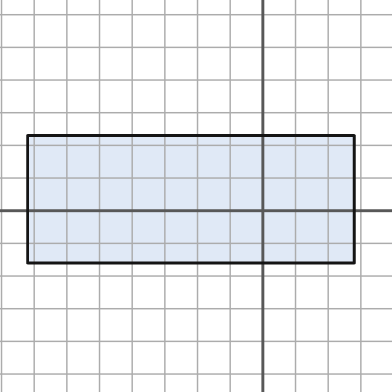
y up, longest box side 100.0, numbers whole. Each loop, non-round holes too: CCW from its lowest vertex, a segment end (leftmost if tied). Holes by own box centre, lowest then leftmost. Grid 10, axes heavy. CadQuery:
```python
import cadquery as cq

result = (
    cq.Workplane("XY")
    .moveTo(-72.0, -16.0)
    .lineTo(28.0, -16.0)
    .lineTo(28.0, 23.0)
    .lineTo(-72.0, 23.0)
    .close()
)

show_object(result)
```